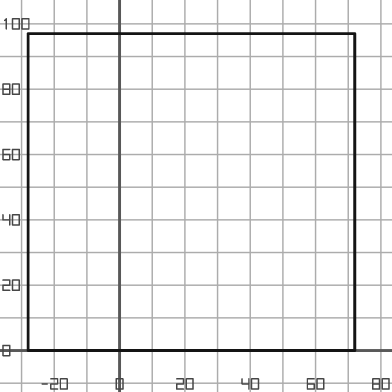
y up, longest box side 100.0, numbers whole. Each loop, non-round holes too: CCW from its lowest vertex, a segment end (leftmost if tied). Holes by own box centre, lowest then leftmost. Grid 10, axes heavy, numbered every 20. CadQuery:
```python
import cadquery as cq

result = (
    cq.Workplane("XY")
    .moveTo(-28.0, 0.0)
    .lineTo(72.0, 0.0)
    .lineTo(72.0, 97.0)
    .lineTo(-28.0, 97.0)
    .close()
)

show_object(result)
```